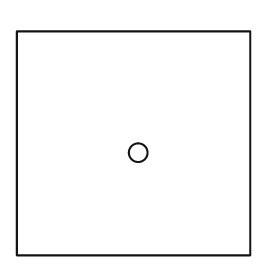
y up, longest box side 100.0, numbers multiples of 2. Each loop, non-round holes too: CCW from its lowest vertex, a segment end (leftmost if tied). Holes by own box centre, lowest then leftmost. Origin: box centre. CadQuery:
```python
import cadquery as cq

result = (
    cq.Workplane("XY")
    .moveTo(-50.0, -48.0)
    .lineTo(50.0, -48.0)
    .lineTo(50.0, 48.0)
    .lineTo(-50.0, 48.0)
    .close()
    .moveTo(2.0, -4.0)
    .circle(4.0)
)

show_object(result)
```